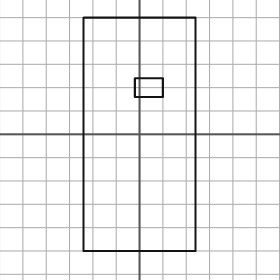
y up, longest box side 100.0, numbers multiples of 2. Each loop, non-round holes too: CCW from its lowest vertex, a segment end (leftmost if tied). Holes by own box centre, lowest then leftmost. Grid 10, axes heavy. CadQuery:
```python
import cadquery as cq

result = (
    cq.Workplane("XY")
    .moveTo(-24.0, -50.0)
    .lineTo(24.0, -50.0)
    .lineTo(24.0, 50.0)
    .lineTo(-24.0, 50.0)
    .close()
    .moveTo(-2.0, 16.0)
    .lineTo(10.0, 16.0)
    .lineTo(10.0, 24.0)
    .lineTo(-2.0, 24.0)
    .close()
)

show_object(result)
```